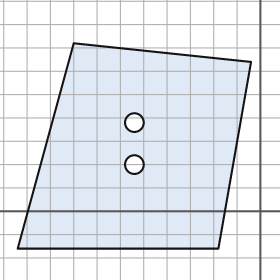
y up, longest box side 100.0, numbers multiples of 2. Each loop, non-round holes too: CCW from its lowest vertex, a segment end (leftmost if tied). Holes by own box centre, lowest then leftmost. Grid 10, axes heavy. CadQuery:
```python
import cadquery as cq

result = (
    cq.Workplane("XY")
    .moveTo(-104.0, -16.0)
    .lineTo(-18.0, -16.0)
    .lineTo(-4.0, 64.0)
    .lineTo(-80.0, 72.0)
    .close()
    .moveTo(-54.0, 20.0)
    .circle(4.0)
    .moveTo(-54.0, 38.0)
    .circle(4.0)
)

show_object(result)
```